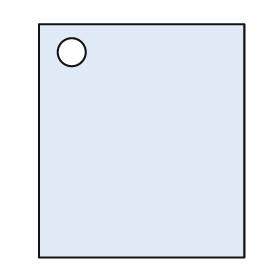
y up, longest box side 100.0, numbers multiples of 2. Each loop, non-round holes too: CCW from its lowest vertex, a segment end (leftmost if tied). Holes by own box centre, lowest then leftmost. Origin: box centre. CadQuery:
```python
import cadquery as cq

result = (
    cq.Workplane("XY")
    .moveTo(-44.0, -50.0)
    .lineTo(44.0, -50.0)
    .lineTo(44.0, 50.0)
    .lineTo(-44.0, 50.0)
    .close()
    .moveTo(-30.0, 38.0)
    .circle(6.0)
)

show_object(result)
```